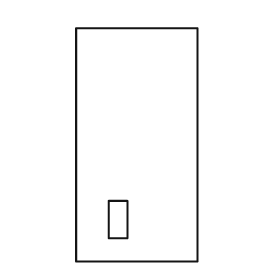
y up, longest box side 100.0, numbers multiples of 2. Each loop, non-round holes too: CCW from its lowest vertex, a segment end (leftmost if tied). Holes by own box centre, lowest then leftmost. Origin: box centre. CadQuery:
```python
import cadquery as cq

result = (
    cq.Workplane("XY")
    .moveTo(-26.0, -50.0)
    .lineTo(26.0, -50.0)
    .lineTo(26.0, 50.0)
    .lineTo(-26.0, 50.0)
    .close()
    .moveTo(-12.0, -40.0)
    .lineTo(-4.0, -40.0)
    .lineTo(-4.0, -24.0)
    .lineTo(-12.0, -24.0)
    .close()
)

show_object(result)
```